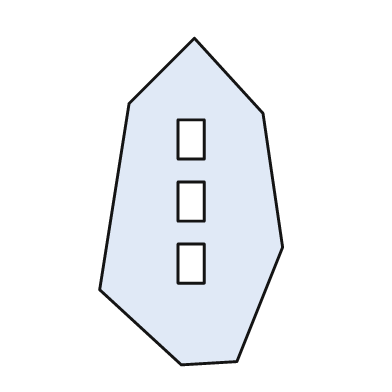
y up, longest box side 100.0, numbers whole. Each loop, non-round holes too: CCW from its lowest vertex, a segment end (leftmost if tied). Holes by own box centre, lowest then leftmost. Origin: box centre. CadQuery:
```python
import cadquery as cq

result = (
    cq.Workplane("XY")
    .moveTo(-3.0, -50.0)
    .lineTo(14.0, -49.0)
    .lineTo(28.0, -14.0)
    .lineTo(22.0, 27.0)
    .lineTo(1.0, 50.0)
    .lineTo(-19.0, 30.0)
    .lineTo(-28.0, -27.0)
    .close()
    .moveTo(-4.0, -25.0)
    .lineTo(4.0, -25.0)
    .lineTo(4.0, -13.0)
    .lineTo(-4.0, -13.0)
    .close()
    .moveTo(-4.0, -6.0)
    .lineTo(4.0, -6.0)
    .lineTo(4.0, 6.0)
    .lineTo(-4.0, 6.0)
    .close()
    .moveTo(-4.0, 13.0)
    .lineTo(4.0, 13.0)
    .lineTo(4.0, 25.0)
    .lineTo(-4.0, 25.0)
    .close()
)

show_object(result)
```